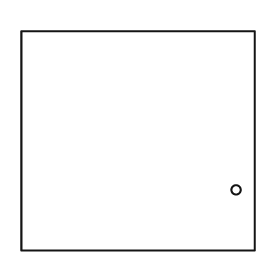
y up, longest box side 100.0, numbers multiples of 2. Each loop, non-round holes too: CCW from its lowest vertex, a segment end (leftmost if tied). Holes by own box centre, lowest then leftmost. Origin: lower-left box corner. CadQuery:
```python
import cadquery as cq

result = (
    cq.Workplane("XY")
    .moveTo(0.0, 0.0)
    .lineTo(100.0, 0.0)
    .lineTo(100.0, 94.0)
    .lineTo(0.0, 94.0)
    .close()
    .moveTo(92.0, 26.0)
    .circle(2.0)
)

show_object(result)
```